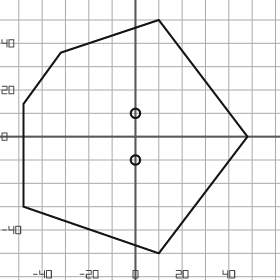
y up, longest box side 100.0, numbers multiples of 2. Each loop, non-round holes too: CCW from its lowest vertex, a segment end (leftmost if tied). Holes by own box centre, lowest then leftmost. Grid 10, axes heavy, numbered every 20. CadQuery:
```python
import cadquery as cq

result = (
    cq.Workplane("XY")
    .moveTo(10.0, -50.0)
    .lineTo(48.0, 0.0)
    .lineTo(10.0, 50.0)
    .lineTo(-32.0, 36.0)
    .lineTo(-48.0, 14.0)
    .lineTo(-48.0, -30.0)
    .close()
    .moveTo(0.0, -10.0)
    .circle(2.0)
    .moveTo(0.0, 10.0)
    .circle(2.0)
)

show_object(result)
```